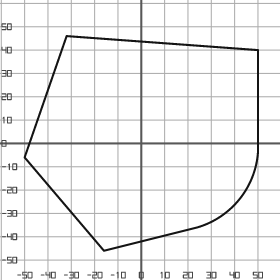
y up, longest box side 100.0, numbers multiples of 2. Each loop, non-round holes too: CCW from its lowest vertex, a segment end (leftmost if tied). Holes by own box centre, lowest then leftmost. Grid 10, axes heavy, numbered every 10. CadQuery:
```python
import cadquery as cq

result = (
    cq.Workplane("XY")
    .moveTo(-16.0, -46.0)
    .lineTo(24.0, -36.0)
    .threePointArc((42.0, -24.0), (50.0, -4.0))
    .lineTo(50.0, 40.0)
    .lineTo(-32.0, 46.0)
    .lineTo(-50.0, -6.0)
    .close()
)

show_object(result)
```